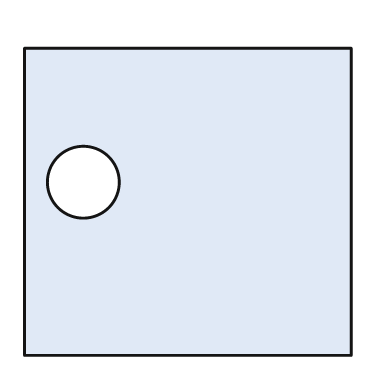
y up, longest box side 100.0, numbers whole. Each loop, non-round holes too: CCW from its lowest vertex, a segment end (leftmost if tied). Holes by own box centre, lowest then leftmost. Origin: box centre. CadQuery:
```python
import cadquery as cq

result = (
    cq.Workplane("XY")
    .moveTo(-50.0, -47.0)
    .lineTo(50.0, -47.0)
    .lineTo(50.0, 47.0)
    .lineTo(-50.0, 47.0)
    .close()
    .moveTo(-32.0, 6.0)
    .circle(11.0)
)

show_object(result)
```